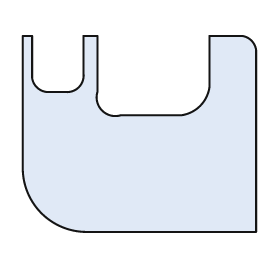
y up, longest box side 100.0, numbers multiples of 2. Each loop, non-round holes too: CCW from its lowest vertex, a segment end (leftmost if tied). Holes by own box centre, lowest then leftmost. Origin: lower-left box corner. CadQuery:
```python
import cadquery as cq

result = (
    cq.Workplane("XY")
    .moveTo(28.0, 0.0)
    .lineTo(100.0, 0.0)
    .lineTo(100.0, 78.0)
    .threePointArc((98.0, 82.0), (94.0, 84.0))
    .lineTo(80.0, 84.0)
    .lineTo(80.0, 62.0)
    .threePointArc((76.0, 54.0), (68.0, 50.0))
    .lineTo(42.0, 50.0)
    .threePointArc((34.0, 52.0), (32.0, 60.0))
    .lineTo(32.0, 84.0)
    .lineTo(26.0, 84.0)
    .lineTo(26.0, 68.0)
    .threePointArc((24.0, 62.0), (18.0, 60.0))
    .lineTo(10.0, 60.0)
    .threePointArc((6.0, 62.0), (4.0, 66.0))
    .lineTo(4.0, 84.0)
    .lineTo(0.0, 84.0)
    .lineTo(0.0, 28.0)
    .threePointArc((8.0, 8.0), (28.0, 0.0))
    .close()
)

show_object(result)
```